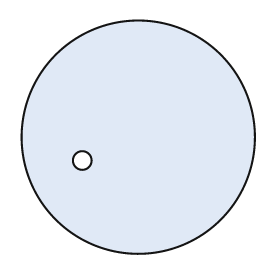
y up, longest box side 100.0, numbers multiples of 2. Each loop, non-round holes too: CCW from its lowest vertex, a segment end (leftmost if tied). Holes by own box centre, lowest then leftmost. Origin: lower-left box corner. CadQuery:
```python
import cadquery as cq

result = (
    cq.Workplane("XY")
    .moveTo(50.0, 50.0)
    .circle(50.0)
    .moveTo(26.0, 40.0)
    .circle(4.0)
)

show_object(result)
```